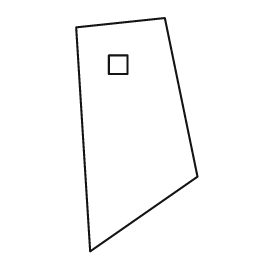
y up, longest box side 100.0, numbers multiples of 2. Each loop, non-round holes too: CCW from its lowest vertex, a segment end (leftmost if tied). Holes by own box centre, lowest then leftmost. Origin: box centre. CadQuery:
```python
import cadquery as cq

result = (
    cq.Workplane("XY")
    .moveTo(-20.0, -50.0)
    .lineTo(26.0, -18.0)
    .lineTo(12.0, 50.0)
    .lineTo(-26.0, 46.0)
    .close()
    .moveTo(-12.0, 26.0)
    .lineTo(-4.0, 26.0)
    .lineTo(-4.0, 34.0)
    .lineTo(-12.0, 34.0)
    .close()
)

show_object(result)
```